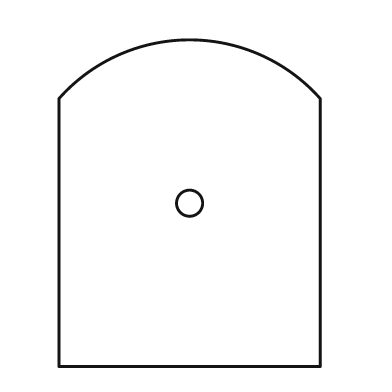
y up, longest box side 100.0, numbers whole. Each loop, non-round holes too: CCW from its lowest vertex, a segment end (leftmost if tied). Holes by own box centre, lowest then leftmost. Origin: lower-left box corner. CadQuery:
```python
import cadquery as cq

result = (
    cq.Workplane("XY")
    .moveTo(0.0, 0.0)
    .lineTo(80.0, 0.0)
    .lineTo(80.0, 82.0)
    .threePointArc((40.0, 100.0), (0.0, 82.0))
    .close()
    .moveTo(40.0, 50.0)
    .circle(4.0)
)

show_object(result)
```